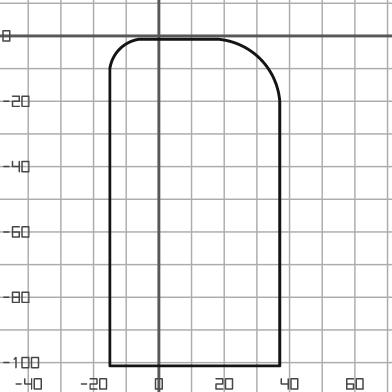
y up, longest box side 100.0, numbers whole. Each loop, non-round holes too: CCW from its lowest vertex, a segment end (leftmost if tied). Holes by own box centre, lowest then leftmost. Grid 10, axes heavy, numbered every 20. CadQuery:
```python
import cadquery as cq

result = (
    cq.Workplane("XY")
    .moveTo(-15.0, -101.0)
    .lineTo(37.0, -101.0)
    .lineTo(37.0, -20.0)
    .threePointArc((31.0, -7.0), (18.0, -1.0))
    .lineTo(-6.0, -1.0)
    .threePointArc((-12.0, -4.0), (-15.0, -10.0))
    .close()
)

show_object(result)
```